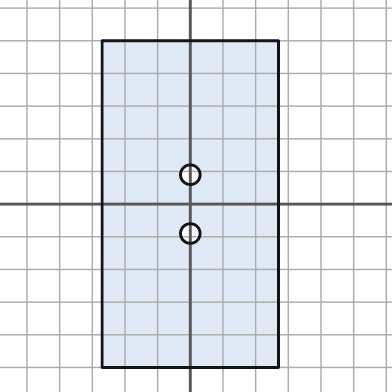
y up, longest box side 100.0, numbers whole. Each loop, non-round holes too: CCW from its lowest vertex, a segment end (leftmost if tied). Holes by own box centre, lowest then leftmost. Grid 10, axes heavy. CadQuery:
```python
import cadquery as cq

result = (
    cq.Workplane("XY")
    .moveTo(-27.0, -50.0)
    .lineTo(27.0, -50.0)
    .lineTo(27.0, 50.0)
    .lineTo(-27.0, 50.0)
    .close()
    .moveTo(0.0, -9.0)
    .circle(3.0)
    .moveTo(0.0, 9.0)
    .circle(3.0)
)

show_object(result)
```